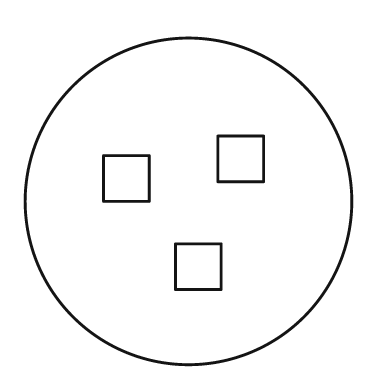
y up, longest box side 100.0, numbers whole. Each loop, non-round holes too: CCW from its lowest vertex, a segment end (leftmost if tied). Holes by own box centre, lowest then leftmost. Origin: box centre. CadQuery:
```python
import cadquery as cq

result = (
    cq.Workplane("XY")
    .moveTo(0.0, 0.0)
    .circle(50.0)
    .moveTo(-4.0, -27.0)
    .lineTo(10.0, -27.0)
    .lineTo(10.0, -13.0)
    .lineTo(-4.0, -13.0)
    .close()
    .moveTo(-26.0, 0.0)
    .lineTo(-12.0, 0.0)
    .lineTo(-12.0, 14.0)
    .lineTo(-26.0, 14.0)
    .close()
    .moveTo(9.0, 6.0)
    .lineTo(23.0, 6.0)
    .lineTo(23.0, 20.0)
    .lineTo(9.0, 20.0)
    .close()
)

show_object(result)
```